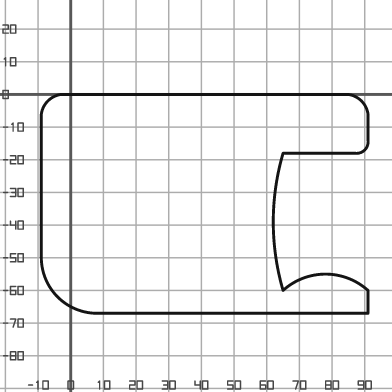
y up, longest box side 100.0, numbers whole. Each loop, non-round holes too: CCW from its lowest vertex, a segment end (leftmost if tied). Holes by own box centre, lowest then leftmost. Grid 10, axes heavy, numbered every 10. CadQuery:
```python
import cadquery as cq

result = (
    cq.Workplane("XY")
    .moveTo(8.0, -67.0)
    .lineTo(91.0, -67.0)
    .lineTo(91.0, -60.0)
    .threePointArc((78.0, -55.0), (65.0, -60.0))
    .threePointArc((62.0, -39.0), (65.0, -18.0))
    .lineTo(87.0, -18.0)
    .threePointArc((90.0, -17.0), (91.0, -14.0))
    .lineTo(91.0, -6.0)
    .threePointArc((89.0, -2.0), (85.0, 0.0))
    .lineTo(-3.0, 0.0)
    .threePointArc((-7.0, -2.0), (-9.0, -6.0))
    .lineTo(-9.0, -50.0)
    .threePointArc((-4.0, -62.0), (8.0, -67.0))
    .close()
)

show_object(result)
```